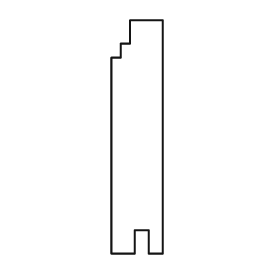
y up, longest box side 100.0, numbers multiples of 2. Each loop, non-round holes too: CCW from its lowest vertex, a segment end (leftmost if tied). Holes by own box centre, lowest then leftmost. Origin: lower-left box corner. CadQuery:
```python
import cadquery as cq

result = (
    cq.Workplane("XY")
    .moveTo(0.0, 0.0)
    .lineTo(10.0, 0.0)
    .lineTo(10.0, 10.0)
    .lineTo(16.0, 10.0)
    .lineTo(16.0, 0.0)
    .lineTo(22.0, 0.0)
    .lineTo(22.0, 100.0)
    .lineTo(8.0, 100.0)
    .lineTo(8.0, 90.0)
    .lineTo(4.0, 90.0)
    .lineTo(4.0, 84.0)
    .lineTo(0.0, 84.0)
    .close()
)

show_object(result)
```